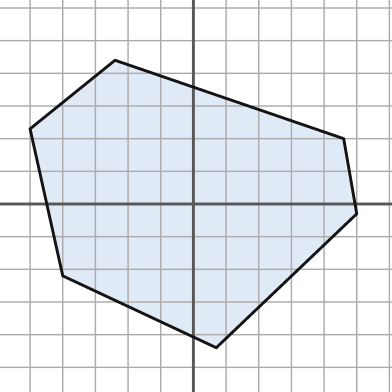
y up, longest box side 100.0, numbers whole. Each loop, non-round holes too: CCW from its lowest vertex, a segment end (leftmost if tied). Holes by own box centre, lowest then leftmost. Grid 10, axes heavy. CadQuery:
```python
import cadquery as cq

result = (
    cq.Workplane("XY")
    .moveTo(7.0, -44.0)
    .lineTo(50.0, -3.0)
    .lineTo(46.0, 20.0)
    .lineTo(-24.0, 44.0)
    .lineTo(-50.0, 23.0)
    .lineTo(-40.0, -22.0)
    .close()
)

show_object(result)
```